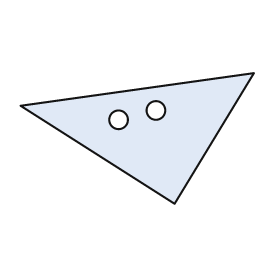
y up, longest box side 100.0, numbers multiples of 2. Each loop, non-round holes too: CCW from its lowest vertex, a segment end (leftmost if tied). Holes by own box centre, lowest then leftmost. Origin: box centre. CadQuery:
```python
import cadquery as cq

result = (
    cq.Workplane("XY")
    .moveTo(16.0, -28.0)
    .lineTo(50.0, 28.0)
    .lineTo(-50.0, 14.0)
    .close()
    .moveTo(-8.0, 8.0)
    .circle(4.0)
    .moveTo(8.0, 12.0)
    .circle(4.0)
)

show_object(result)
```